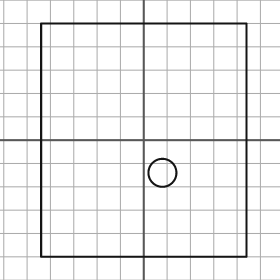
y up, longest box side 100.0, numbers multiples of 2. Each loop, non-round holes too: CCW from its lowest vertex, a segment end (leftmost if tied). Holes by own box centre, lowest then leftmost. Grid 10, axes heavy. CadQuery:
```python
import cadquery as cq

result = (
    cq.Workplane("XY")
    .moveTo(-44.0, -50.0)
    .lineTo(44.0, -50.0)
    .lineTo(44.0, 50.0)
    .lineTo(-44.0, 50.0)
    .close()
    .moveTo(8.0, -14.0)
    .circle(6.0)
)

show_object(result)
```